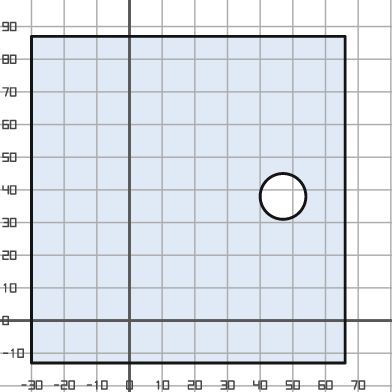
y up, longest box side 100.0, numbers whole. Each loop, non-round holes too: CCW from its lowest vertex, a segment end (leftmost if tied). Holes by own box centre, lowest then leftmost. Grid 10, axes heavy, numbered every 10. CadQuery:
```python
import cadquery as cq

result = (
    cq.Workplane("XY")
    .moveTo(-30.0, -13.0)
    .lineTo(66.0, -13.0)
    .lineTo(66.0, 87.0)
    .lineTo(-30.0, 87.0)
    .close()
    .moveTo(47.0, 38.0)
    .circle(7.0)
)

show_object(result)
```